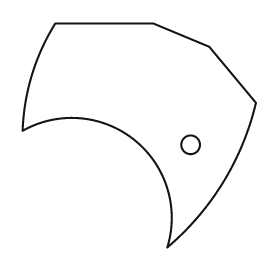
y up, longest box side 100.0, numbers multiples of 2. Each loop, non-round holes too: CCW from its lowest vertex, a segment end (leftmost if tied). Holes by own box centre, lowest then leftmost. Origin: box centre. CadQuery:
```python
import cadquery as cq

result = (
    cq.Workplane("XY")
    .moveTo(12.0, -48.0)
    .threePointArc((36.0, -20.0), (50.0, 14.0))
    .lineTo(30.0, 38.0)
    .lineTo(6.0, 48.0)
    .lineTo(-36.0, 48.0)
    .threePointArc((-46.0, 26.0), (-50.0, 2.0))
    .threePointArc((-2.0, -2.0), (12.0, -48.0))
    .close()
    .moveTo(22.0, -4.0)
    .circle(4.0)
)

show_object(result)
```